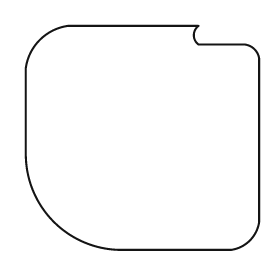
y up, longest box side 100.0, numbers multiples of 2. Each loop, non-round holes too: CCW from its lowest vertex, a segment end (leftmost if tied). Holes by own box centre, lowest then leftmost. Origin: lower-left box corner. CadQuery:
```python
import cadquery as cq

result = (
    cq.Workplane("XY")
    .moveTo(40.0, 0.0)
    .lineTo(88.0, 0.0)
    .threePointArc((96.0, 4.0), (100.0, 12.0))
    .lineTo(100.0, 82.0)
    .threePointArc((98.0, 86.0), (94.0, 88.0))
    .lineTo(74.0, 88.0)
    .threePointArc((72.0, 92.0), (74.0, 96.0))
    .lineTo(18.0, 96.0)
    .threePointArc((6.0, 90.0), (0.0, 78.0))
    .lineTo(0.0, 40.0)
    .threePointArc((12.0, 12.0), (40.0, 0.0))
    .close()
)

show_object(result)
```